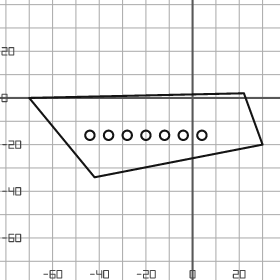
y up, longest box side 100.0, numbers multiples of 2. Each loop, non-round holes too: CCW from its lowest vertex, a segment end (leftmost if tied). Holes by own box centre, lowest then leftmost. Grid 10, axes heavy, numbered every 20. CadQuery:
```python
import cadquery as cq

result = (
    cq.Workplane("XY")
    .moveTo(-42.0, -34.0)
    .lineTo(30.0, -20.0)
    .lineTo(22.0, 2.0)
    .lineTo(-70.0, 0.0)
    .close()
    .moveTo(-44.0, -16.0)
    .circle(2.0)
    .moveTo(-36.0, -16.0)
    .circle(2.0)
    .moveTo(-28.0, -16.0)
    .circle(2.0)
    .moveTo(-20.0, -16.0)
    .circle(2.0)
    .moveTo(-12.0, -16.0)
    .circle(2.0)
    .moveTo(-4.0, -16.0)
    .circle(2.0)
    .moveTo(4.0, -16.0)
    .circle(2.0)
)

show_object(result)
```